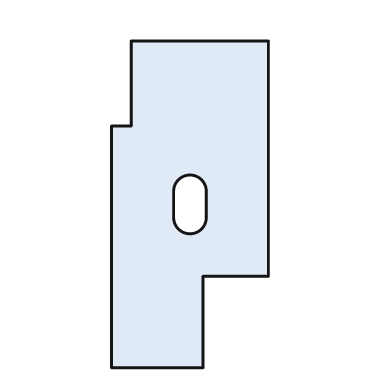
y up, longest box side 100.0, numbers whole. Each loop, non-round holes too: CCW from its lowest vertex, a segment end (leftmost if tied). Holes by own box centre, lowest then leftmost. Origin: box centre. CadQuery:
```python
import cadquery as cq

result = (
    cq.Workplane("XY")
    .moveTo(-24.0, -50.0)
    .lineTo(4.0, -50.0)
    .lineTo(4.0, -22.0)
    .lineTo(24.0, -22.0)
    .lineTo(24.0, 50.0)
    .lineTo(-18.0, 50.0)
    .lineTo(-18.0, 24.0)
    .lineTo(-24.0, 24.0)
    .close()
    .moveTo(-5.0, -4.0)
    .threePointArc((0.0, -9.0), (5.0, -4.0))
    .lineTo(5.0, 4.0)
    .threePointArc((0.0, 9.0), (-5.0, 4.0))
    .close()
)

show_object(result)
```